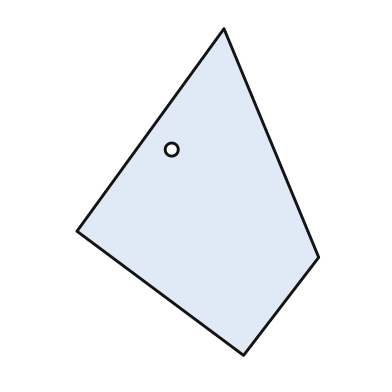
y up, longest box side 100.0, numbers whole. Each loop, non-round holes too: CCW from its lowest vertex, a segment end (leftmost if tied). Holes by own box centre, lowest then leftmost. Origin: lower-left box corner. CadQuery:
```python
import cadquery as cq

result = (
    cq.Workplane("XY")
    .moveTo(51.0, 0.0)
    .lineTo(74.0, 30.0)
    .lineTo(45.0, 100.0)
    .lineTo(0.0, 38.0)
    .close()
    .moveTo(29.0, 63.0)
    .circle(2.0)
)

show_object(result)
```